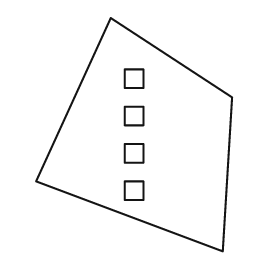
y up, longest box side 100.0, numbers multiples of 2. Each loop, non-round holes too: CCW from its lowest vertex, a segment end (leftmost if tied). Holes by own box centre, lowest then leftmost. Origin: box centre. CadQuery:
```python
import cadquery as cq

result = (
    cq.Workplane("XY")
    .moveTo(38.0, -50.0)
    .lineTo(42.0, 16.0)
    .lineTo(-10.0, 50.0)
    .lineTo(-42.0, -20.0)
    .close()
    .moveTo(-4.0, -28.0)
    .lineTo(4.0, -28.0)
    .lineTo(4.0, -20.0)
    .lineTo(-4.0, -20.0)
    .close()
    .moveTo(-4.0, -12.0)
    .lineTo(4.0, -12.0)
    .lineTo(4.0, -4.0)
    .lineTo(-4.0, -4.0)
    .close()
    .moveTo(-4.0, 4.0)
    .lineTo(4.0, 4.0)
    .lineTo(4.0, 12.0)
    .lineTo(-4.0, 12.0)
    .close()
    .moveTo(-4.0, 20.0)
    .lineTo(4.0, 20.0)
    .lineTo(4.0, 28.0)
    .lineTo(-4.0, 28.0)
    .close()
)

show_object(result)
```